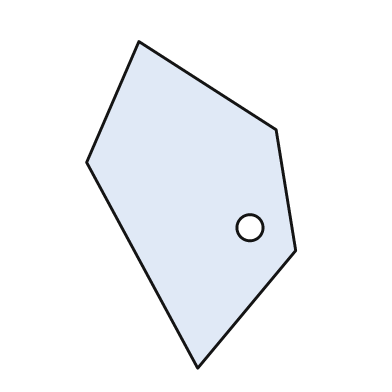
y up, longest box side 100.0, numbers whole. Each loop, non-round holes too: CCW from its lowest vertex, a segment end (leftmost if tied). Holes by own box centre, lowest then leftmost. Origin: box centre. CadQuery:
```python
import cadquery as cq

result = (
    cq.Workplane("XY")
    .moveTo(2.0, -50.0)
    .lineTo(32.0, -14.0)
    .lineTo(26.0, 23.0)
    .lineTo(-16.0, 50.0)
    .lineTo(-32.0, 13.0)
    .close()
    .moveTo(18.0, -7.0)
    .circle(4.0)
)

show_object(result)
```